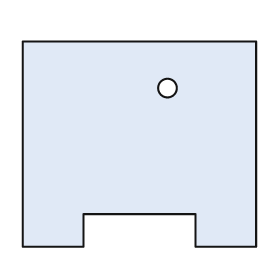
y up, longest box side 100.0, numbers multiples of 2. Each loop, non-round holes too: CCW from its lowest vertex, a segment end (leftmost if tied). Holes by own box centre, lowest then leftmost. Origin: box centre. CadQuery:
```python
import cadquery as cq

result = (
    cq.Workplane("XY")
    .moveTo(-50.0, -44.0)
    .lineTo(-24.0, -44.0)
    .lineTo(-24.0, -30.0)
    .lineTo(24.0, -30.0)
    .lineTo(24.0, -44.0)
    .lineTo(50.0, -44.0)
    .lineTo(50.0, 44.0)
    .lineTo(-50.0, 44.0)
    .close()
    .moveTo(12.0, 24.0)
    .circle(4.0)
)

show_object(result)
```